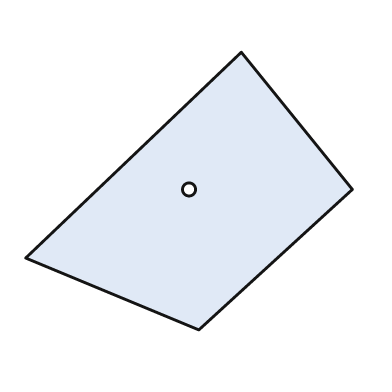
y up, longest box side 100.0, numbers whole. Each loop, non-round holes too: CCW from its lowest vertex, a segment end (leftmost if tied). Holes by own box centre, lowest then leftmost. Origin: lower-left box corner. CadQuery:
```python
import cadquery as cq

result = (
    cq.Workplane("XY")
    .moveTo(53.0, 0.0)
    .lineTo(100.0, 43.0)
    .lineTo(66.0, 85.0)
    .lineTo(0.0, 22.0)
    .close()
    .moveTo(50.0, 43.0)
    .circle(2.0)
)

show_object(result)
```